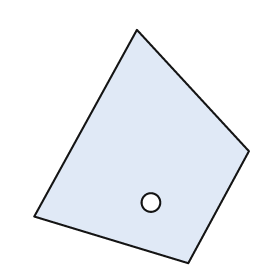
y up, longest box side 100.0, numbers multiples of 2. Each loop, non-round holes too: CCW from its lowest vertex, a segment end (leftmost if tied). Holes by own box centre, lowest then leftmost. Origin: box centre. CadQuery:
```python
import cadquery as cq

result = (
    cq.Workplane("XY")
    .moveTo(20.0, -50.0)
    .lineTo(46.0, -2.0)
    .lineTo(-2.0, 50.0)
    .lineTo(-46.0, -30.0)
    .close()
    .moveTo(4.0, -24.0)
    .circle(4.0)
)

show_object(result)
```